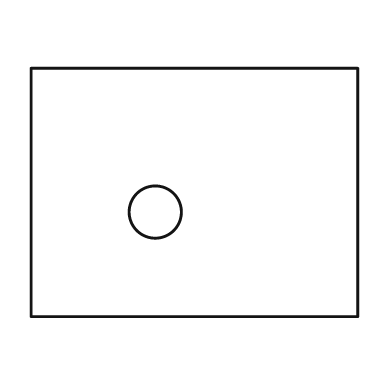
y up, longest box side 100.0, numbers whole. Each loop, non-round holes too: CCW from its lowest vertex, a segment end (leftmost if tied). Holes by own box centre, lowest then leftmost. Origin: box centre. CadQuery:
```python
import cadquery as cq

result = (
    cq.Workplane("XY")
    .moveTo(-50.0, -38.0)
    .lineTo(50.0, -38.0)
    .lineTo(50.0, 38.0)
    .lineTo(-50.0, 38.0)
    .close()
    .moveTo(-12.0, -6.0)
    .circle(8.0)
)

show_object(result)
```